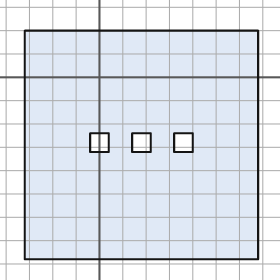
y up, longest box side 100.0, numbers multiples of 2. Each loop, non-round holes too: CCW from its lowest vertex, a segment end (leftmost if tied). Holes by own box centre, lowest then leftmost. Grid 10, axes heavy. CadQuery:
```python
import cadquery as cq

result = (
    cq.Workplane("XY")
    .moveTo(-32.0, -78.0)
    .lineTo(68.0, -78.0)
    .lineTo(68.0, 20.0)
    .lineTo(-32.0, 20.0)
    .close()
    .moveTo(-4.0, -32.0)
    .lineTo(4.0, -32.0)
    .lineTo(4.0, -24.0)
    .lineTo(-4.0, -24.0)
    .close()
    .moveTo(14.0, -32.0)
    .lineTo(22.0, -32.0)
    .lineTo(22.0, -24.0)
    .lineTo(14.0, -24.0)
    .close()
    .moveTo(32.0, -32.0)
    .lineTo(40.0, -32.0)
    .lineTo(40.0, -24.0)
    .lineTo(32.0, -24.0)
    .close()
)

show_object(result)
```